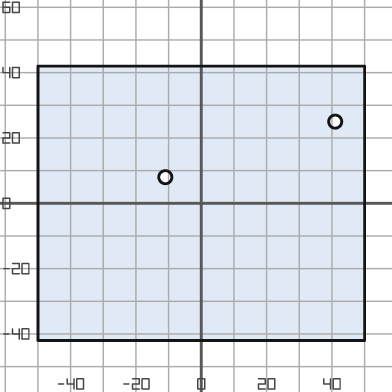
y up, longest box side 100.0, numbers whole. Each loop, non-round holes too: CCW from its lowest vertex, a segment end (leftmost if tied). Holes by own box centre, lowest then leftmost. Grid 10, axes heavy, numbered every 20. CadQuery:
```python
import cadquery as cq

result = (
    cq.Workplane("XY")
    .moveTo(-50.0, -42.0)
    .lineTo(50.0, -42.0)
    .lineTo(50.0, 42.0)
    .lineTo(-50.0, 42.0)
    .close()
    .moveTo(-11.0, 8.0)
    .circle(2.0)
    .moveTo(41.0, 25.0)
    .circle(2.0)
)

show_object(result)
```